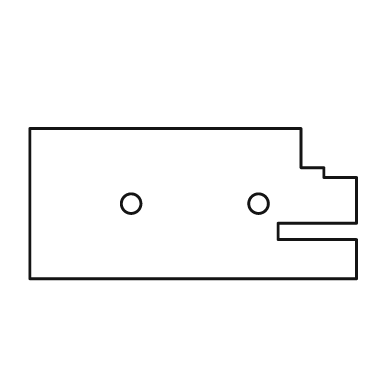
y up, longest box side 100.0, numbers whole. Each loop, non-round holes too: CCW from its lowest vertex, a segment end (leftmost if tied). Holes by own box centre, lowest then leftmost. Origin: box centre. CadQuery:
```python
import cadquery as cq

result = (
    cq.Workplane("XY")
    .moveTo(-50.0, -23.0)
    .lineTo(50.0, -23.0)
    .lineTo(50.0, -11.0)
    .lineTo(26.0, -11.0)
    .lineTo(26.0, -6.0)
    .lineTo(50.0, -6.0)
    .lineTo(50.0, 8.0)
    .lineTo(40.0, 8.0)
    .lineTo(40.0, 11.0)
    .lineTo(33.0, 11.0)
    .lineTo(33.0, 23.0)
    .lineTo(-50.0, 23.0)
    .close()
    .moveTo(-19.0, 0.0)
    .circle(3.0)
    .moveTo(20.0, 0.0)
    .circle(3.0)
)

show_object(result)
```